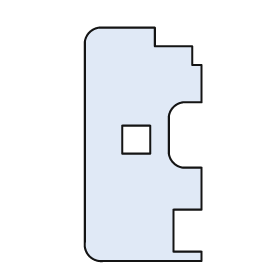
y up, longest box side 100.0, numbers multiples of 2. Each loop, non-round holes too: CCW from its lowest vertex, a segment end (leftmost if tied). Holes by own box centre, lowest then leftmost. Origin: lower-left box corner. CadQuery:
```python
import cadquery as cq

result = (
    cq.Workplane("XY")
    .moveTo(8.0, 0.0)
    .lineTo(50.0, 0.0)
    .lineTo(50.0, 4.0)
    .lineTo(38.0, 4.0)
    .lineTo(38.0, 22.0)
    .lineTo(50.0, 22.0)
    .lineTo(50.0, 40.0)
    .lineTo(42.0, 40.0)
    .threePointArc((38.0, 42.0), (36.0, 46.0))
    .lineTo(36.0, 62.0)
    .threePointArc((38.0, 66.0), (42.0, 68.0))
    .lineTo(50.0, 68.0)
    .lineTo(50.0, 84.0)
    .lineTo(46.0, 84.0)
    .lineTo(46.0, 92.0)
    .lineTo(30.0, 92.0)
    .lineTo(30.0, 100.0)
    .lineTo(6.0, 100.0)
    .threePointArc((2.0, 98.0), (0.0, 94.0))
    .lineTo(0.0, 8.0)
    .threePointArc((2.0, 2.0), (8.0, 0.0))
    .close()
    .moveTo(16.0, 46.0)
    .lineTo(28.0, 46.0)
    .lineTo(28.0, 58.0)
    .lineTo(16.0, 58.0)
    .close()
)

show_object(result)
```